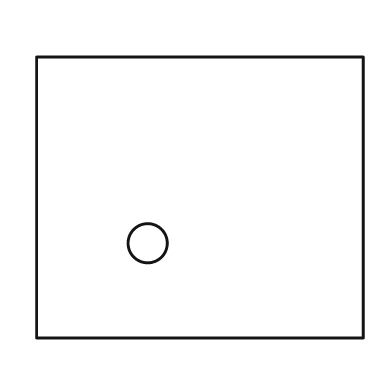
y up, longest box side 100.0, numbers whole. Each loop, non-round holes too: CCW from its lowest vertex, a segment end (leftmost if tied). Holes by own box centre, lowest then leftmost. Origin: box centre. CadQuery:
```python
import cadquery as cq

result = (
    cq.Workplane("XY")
    .moveTo(-50.0, -43.0)
    .lineTo(50.0, -43.0)
    .lineTo(50.0, 43.0)
    .lineTo(-50.0, 43.0)
    .close()
    .moveTo(-16.0, -14.0)
    .circle(6.0)
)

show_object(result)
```